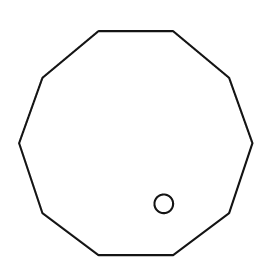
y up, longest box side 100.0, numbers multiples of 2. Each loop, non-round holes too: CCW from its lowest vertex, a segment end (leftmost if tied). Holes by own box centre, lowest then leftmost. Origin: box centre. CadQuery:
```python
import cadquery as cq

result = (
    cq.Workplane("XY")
    .moveTo(-16.0, -48.0)
    .lineTo(16.0, -48.0)
    .lineTo(40.0, -30.0)
    .lineTo(50.0, 0.0)
    .lineTo(40.0, 28.0)
    .lineTo(16.0, 48.0)
    .lineTo(-16.0, 48.0)
    .lineTo(-40.0, 28.0)
    .lineTo(-50.0, 0.0)
    .lineTo(-40.0, -30.0)
    .close()
    .moveTo(12.0, -26.0)
    .circle(4.0)
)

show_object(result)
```